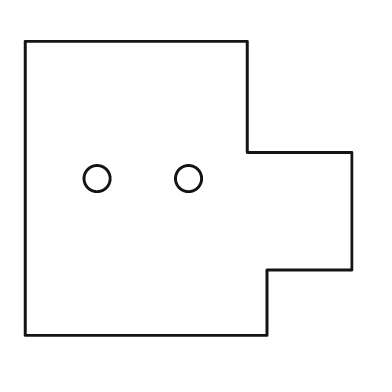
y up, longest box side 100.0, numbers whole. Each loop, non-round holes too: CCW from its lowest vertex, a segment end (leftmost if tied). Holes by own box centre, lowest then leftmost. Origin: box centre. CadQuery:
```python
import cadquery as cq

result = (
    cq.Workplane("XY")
    .moveTo(-50.0, -45.0)
    .lineTo(24.0, -45.0)
    .lineTo(24.0, -25.0)
    .lineTo(50.0, -25.0)
    .lineTo(50.0, 11.0)
    .lineTo(18.0, 11.0)
    .lineTo(18.0, 45.0)
    .lineTo(-50.0, 45.0)
    .close()
    .moveTo(-28.0, 3.0)
    .circle(4.0)
    .moveTo(0.0, 3.0)
    .circle(4.0)
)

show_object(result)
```